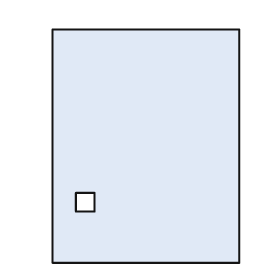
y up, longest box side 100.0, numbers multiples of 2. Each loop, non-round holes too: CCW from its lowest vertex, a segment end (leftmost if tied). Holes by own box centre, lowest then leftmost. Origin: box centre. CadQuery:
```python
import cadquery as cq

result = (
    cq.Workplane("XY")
    .moveTo(-40.0, -50.0)
    .lineTo(40.0, -50.0)
    .lineTo(40.0, 50.0)
    .lineTo(-40.0, 50.0)
    .close()
    .moveTo(-30.0, -28.0)
    .lineTo(-22.0, -28.0)
    .lineTo(-22.0, -20.0)
    .lineTo(-30.0, -20.0)
    .close()
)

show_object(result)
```